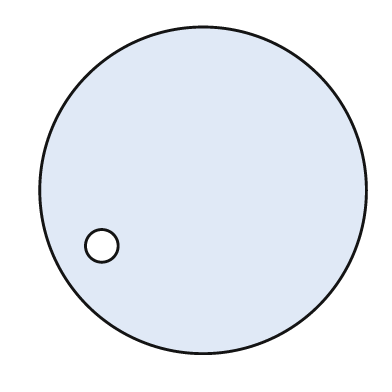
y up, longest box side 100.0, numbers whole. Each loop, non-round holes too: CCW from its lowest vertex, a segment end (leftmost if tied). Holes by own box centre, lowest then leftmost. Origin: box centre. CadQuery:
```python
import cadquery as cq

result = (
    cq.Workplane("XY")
    .moveTo(0.0, 0.0)
    .circle(50.0)
    .moveTo(-31.0, -17.0)
    .circle(5.0)
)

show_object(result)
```